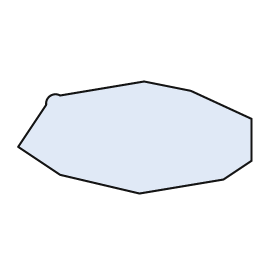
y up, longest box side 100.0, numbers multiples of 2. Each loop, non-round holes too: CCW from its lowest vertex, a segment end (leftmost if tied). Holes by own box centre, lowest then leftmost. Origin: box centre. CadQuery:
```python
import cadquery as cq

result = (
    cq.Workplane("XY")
    .moveTo(2.0, -24.0)
    .lineTo(38.0, -18.0)
    .lineTo(50.0, -10.0)
    .lineTo(50.0, 8.0)
    .lineTo(24.0, 20.0)
    .lineTo(4.0, 24.0)
    .lineTo(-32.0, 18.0)
    .threePointArc((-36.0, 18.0), (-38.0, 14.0))
    .lineTo(-50.0, -4.0)
    .lineTo(-32.0, -16.0)
    .close()
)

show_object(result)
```